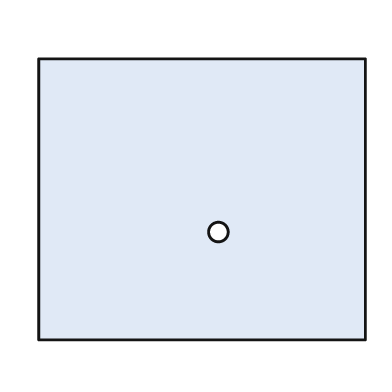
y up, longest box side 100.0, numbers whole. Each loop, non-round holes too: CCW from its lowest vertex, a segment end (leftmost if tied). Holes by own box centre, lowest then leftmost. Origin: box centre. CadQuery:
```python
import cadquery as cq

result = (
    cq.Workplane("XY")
    .moveTo(-50.0, -43.0)
    .lineTo(50.0, -43.0)
    .lineTo(50.0, 43.0)
    .lineTo(-50.0, 43.0)
    .close()
    .moveTo(5.0, -10.0)
    .circle(3.0)
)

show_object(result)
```